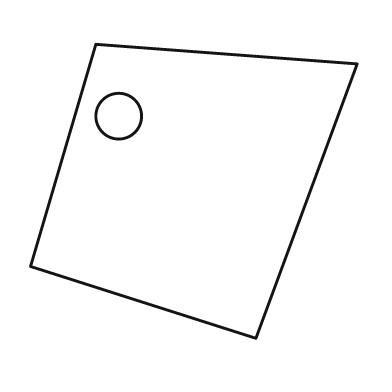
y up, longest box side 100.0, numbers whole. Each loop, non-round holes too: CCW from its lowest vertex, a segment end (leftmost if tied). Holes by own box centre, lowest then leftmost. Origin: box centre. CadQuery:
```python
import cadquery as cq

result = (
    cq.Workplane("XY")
    .moveTo(19.0, -45.0)
    .lineTo(50.0, 39.0)
    .lineTo(-30.0, 45.0)
    .lineTo(-50.0, -23.0)
    .close()
    .moveTo(-23.0, 23.0)
    .circle(7.0)
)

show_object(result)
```